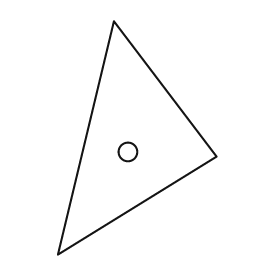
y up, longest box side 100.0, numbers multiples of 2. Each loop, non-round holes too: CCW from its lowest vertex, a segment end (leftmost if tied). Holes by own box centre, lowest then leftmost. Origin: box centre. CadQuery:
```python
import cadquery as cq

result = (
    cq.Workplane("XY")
    .moveTo(-34.0, -50.0)
    .lineTo(34.0, -8.0)
    .lineTo(-10.0, 50.0)
    .close()
    .moveTo(-4.0, -6.0)
    .circle(4.0)
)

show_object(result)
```